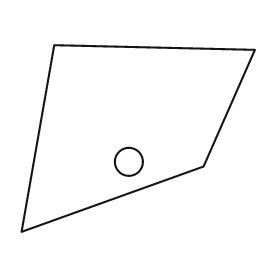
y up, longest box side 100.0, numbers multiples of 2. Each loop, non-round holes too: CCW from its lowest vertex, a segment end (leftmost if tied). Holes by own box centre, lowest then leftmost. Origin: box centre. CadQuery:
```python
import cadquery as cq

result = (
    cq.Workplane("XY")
    .moveTo(-50.0, -40.0)
    .lineTo(28.0, -12.0)
    .lineTo(50.0, 38.0)
    .lineTo(-36.0, 40.0)
    .close()
    .moveTo(-4.0, -10.0)
    .circle(6.0)
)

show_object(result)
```